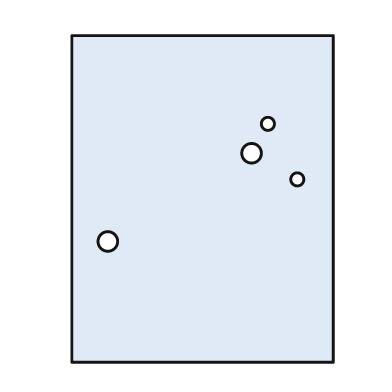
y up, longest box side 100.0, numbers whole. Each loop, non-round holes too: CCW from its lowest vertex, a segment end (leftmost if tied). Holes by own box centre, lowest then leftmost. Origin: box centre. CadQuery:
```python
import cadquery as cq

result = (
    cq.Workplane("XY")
    .moveTo(-40.0, -50.0)
    .lineTo(40.0, -50.0)
    .lineTo(40.0, 50.0)
    .lineTo(-40.0, 50.0)
    .close()
    .moveTo(-29.0, -13.0)
    .circle(3.0)
    .moveTo(29.0, 6.0)
    .circle(2.0)
    .moveTo(15.0, 14.0)
    .circle(3.0)
    .moveTo(20.0, 23.0)
    .circle(2.0)
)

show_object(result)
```